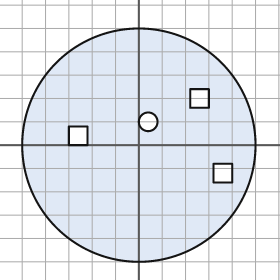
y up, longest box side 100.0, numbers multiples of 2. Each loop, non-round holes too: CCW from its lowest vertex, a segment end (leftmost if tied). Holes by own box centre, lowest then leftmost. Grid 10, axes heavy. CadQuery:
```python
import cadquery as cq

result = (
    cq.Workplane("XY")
    .moveTo(0.0, 0.0)
    .circle(50.0)
    .moveTo(32.0, -16.0)
    .lineTo(40.0, -16.0)
    .lineTo(40.0, -8.0)
    .lineTo(32.0, -8.0)
    .close()
    .moveTo(-30.0, 0.0)
    .lineTo(-22.0, 0.0)
    .lineTo(-22.0, 8.0)
    .lineTo(-30.0, 8.0)
    .close()
    .moveTo(4.0, 10.0)
    .circle(4.0)
    .moveTo(22.0, 16.0)
    .lineTo(30.0, 16.0)
    .lineTo(30.0, 24.0)
    .lineTo(22.0, 24.0)
    .close()
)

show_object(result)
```